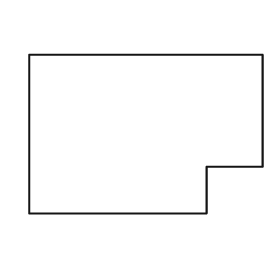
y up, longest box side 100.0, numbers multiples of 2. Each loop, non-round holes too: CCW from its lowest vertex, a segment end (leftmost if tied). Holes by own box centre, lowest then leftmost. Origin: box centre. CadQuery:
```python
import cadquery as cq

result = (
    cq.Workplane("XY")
    .moveTo(-50.0, -34.0)
    .lineTo(26.0, -34.0)
    .lineTo(26.0, -14.0)
    .lineTo(50.0, -14.0)
    .lineTo(50.0, 34.0)
    .lineTo(-50.0, 34.0)
    .close()
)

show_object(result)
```